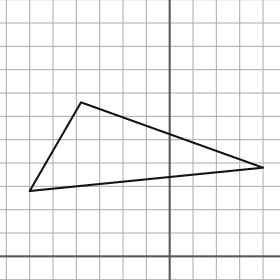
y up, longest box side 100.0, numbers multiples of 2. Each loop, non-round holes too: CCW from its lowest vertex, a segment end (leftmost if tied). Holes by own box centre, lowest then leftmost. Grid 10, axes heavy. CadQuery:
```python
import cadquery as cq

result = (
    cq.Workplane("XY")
    .moveTo(-60.0, 28.0)
    .lineTo(40.0, 38.0)
    .lineTo(-38.0, 66.0)
    .close()
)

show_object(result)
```